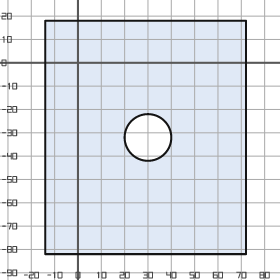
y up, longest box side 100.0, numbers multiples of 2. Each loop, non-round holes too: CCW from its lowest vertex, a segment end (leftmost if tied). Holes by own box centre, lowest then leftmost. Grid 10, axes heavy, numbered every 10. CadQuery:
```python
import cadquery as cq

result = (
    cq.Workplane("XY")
    .moveTo(-14.0, -82.0)
    .lineTo(72.0, -82.0)
    .lineTo(72.0, 18.0)
    .lineTo(-14.0, 18.0)
    .close()
    .moveTo(30.0, -32.0)
    .circle(10.0)
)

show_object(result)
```